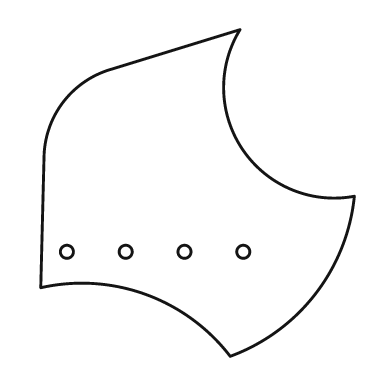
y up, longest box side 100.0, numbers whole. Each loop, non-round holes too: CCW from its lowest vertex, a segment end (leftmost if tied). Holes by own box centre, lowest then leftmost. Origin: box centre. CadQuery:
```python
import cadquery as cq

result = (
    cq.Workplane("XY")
    .moveTo(10.0, -50.0)
    .threePointArc((36.0, -31.0), (48.0, -1.0))
    .threePointArc((14.0, 13.0), (13.0, 50.0))
    .lineTo(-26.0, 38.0)
    .threePointArc((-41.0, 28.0), (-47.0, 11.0))
    .lineTo(-48.0, -29.0)
    .threePointArc((-16.0, -31.0), (10.0, -50.0))
    .close()
    .moveTo(-40.0, -18.0)
    .circle(2.0)
    .moveTo(-22.0, -18.0)
    .circle(2.0)
    .moveTo(-4.0, -18.0)
    .circle(2.0)
    .moveTo(14.0, -18.0)
    .circle(2.0)
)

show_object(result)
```